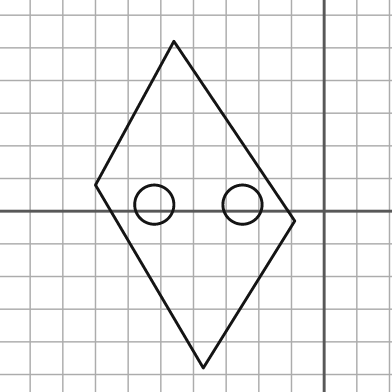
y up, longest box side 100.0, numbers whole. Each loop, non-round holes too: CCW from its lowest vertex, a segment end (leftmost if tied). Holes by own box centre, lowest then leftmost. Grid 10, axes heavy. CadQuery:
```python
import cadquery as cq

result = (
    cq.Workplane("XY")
    .moveTo(-37.0, -48.0)
    .lineTo(-9.0, -3.0)
    .lineTo(-46.0, 52.0)
    .lineTo(-70.0, 8.0)
    .close()
    .moveTo(-52.0, 2.0)
    .circle(6.0)
    .moveTo(-25.0, 2.0)
    .circle(6.0)
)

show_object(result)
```